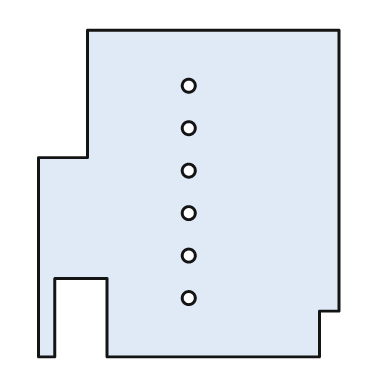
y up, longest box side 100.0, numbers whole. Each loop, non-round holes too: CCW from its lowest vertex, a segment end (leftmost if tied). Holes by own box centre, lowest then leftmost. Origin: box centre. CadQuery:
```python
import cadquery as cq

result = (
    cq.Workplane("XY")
    .moveTo(-46.0, -50.0)
    .lineTo(-41.0, -50.0)
    .lineTo(-41.0, -26.0)
    .lineTo(-25.0, -26.0)
    .lineTo(-25.0, -50.0)
    .lineTo(40.0, -50.0)
    .lineTo(40.0, -36.0)
    .lineTo(46.0, -36.0)
    .lineTo(46.0, 50.0)
    .lineTo(-31.0, 50.0)
    .lineTo(-31.0, 11.0)
    .lineTo(-46.0, 11.0)
    .close()
    .moveTo(0.0, -32.0)
    .circle(2.0)
    .moveTo(0.0, -19.0)
    .circle(2.0)
    .moveTo(0.0, -6.0)
    .circle(2.0)
    .moveTo(0.0, 7.0)
    .circle(2.0)
    .moveTo(0.0, 20.0)
    .circle(2.0)
    .moveTo(0.0, 33.0)
    .circle(2.0)
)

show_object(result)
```